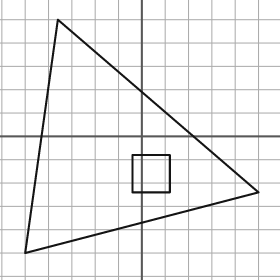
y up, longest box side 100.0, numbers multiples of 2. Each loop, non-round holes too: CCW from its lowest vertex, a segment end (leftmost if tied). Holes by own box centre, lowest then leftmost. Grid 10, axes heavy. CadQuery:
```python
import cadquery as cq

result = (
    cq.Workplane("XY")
    .moveTo(-50.0, -50.0)
    .lineTo(50.0, -24.0)
    .lineTo(-36.0, 50.0)
    .close()
    .moveTo(-4.0, -24.0)
    .lineTo(12.0, -24.0)
    .lineTo(12.0, -8.0)
    .lineTo(-4.0, -8.0)
    .close()
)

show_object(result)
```